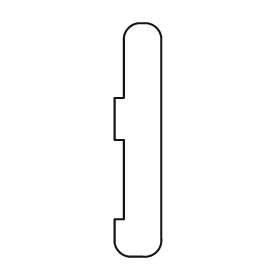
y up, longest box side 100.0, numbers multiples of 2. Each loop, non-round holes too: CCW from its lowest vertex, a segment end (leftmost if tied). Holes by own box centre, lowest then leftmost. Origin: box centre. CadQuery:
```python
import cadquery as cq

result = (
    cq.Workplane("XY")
    .moveTo(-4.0, -50.0)
    .lineTo(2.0, -50.0)
    .threePointArc((8.0, -48.0), (10.0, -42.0))
    .lineTo(10.0, 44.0)
    .threePointArc((8.0, 48.0), (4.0, 50.0))
    .lineTo(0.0, 50.0)
    .threePointArc((-4.0, 48.0), (-6.0, 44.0))
    .lineTo(-6.0, 18.0)
    .lineTo(-10.0, 18.0)
    .lineTo(-10.0, 0.0)
    .lineTo(-6.0, 0.0)
    .lineTo(-6.0, -34.0)
    .lineTo(-10.0, -34.0)
    .lineTo(-10.0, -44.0)
    .threePointArc((-8.0, -48.0), (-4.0, -50.0))
    .close()
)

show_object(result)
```